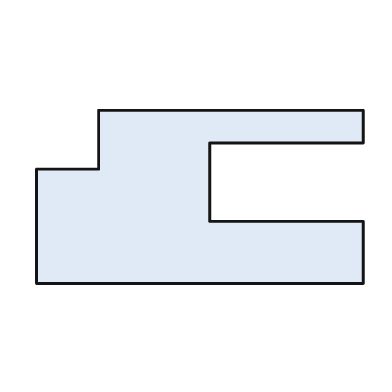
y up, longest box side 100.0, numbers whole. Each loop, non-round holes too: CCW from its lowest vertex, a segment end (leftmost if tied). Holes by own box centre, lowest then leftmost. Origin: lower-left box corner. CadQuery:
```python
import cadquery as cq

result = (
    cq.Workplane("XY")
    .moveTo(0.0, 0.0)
    .lineTo(100.0, 0.0)
    .lineTo(100.0, 19.0)
    .lineTo(53.0, 19.0)
    .lineTo(53.0, 43.0)
    .lineTo(100.0, 43.0)
    .lineTo(100.0, 53.0)
    .lineTo(19.0, 53.0)
    .lineTo(19.0, 35.0)
    .lineTo(0.0, 35.0)
    .close()
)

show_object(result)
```